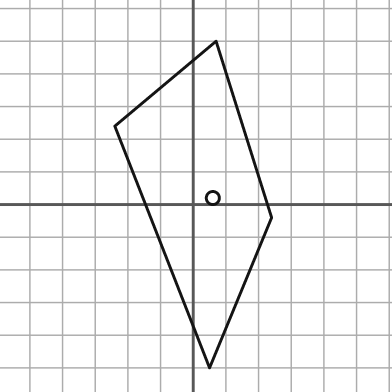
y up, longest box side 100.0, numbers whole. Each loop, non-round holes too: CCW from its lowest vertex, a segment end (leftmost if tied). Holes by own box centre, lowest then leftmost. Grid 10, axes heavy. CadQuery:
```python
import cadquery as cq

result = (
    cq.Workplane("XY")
    .moveTo(5.0, -50.0)
    .lineTo(24.0, -4.0)
    .lineTo(7.0, 50.0)
    .lineTo(-24.0, 24.0)
    .close()
    .moveTo(6.0, 2.0)
    .circle(2.0)
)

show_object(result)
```